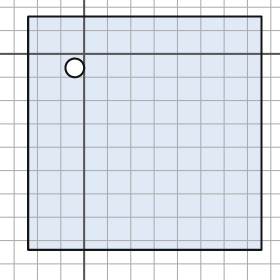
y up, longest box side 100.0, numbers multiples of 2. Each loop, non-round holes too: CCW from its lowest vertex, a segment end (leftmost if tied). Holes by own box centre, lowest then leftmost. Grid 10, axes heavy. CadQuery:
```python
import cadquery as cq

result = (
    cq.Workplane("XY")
    .moveTo(-24.0, -84.0)
    .lineTo(76.0, -84.0)
    .lineTo(76.0, 16.0)
    .lineTo(-24.0, 16.0)
    .close()
    .moveTo(-4.0, -6.0)
    .circle(4.0)
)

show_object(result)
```